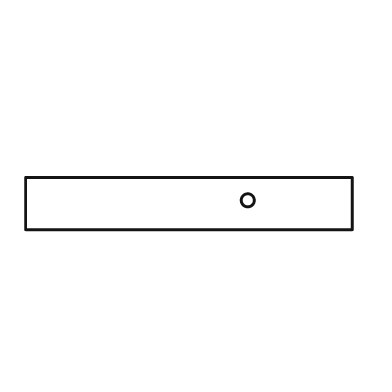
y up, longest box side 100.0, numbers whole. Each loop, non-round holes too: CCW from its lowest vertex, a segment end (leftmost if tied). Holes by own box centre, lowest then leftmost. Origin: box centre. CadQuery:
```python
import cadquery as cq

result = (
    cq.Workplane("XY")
    .moveTo(-50.0, -8.0)
    .lineTo(50.0, -8.0)
    .lineTo(50.0, 8.0)
    .lineTo(-50.0, 8.0)
    .close()
    .moveTo(18.0, 1.0)
    .circle(2.0)
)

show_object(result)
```